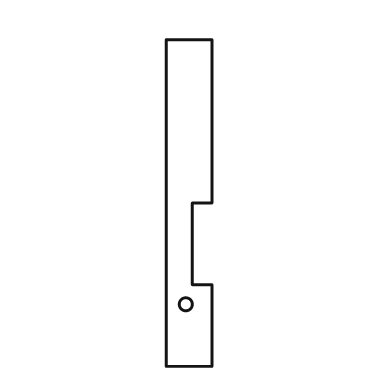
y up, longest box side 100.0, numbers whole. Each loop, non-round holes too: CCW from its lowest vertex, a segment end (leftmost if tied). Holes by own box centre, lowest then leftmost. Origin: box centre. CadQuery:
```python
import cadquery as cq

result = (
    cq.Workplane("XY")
    .moveTo(-7.0, -50.0)
    .lineTo(7.0, -50.0)
    .lineTo(7.0, -25.0)
    .lineTo(1.0, -25.0)
    .lineTo(1.0, 0.0)
    .lineTo(7.0, 0.0)
    .lineTo(7.0, 50.0)
    .lineTo(-7.0, 50.0)
    .close()
    .moveTo(-1.0, -31.0)
    .circle(2.0)
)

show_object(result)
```